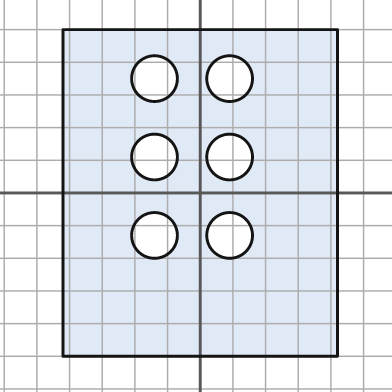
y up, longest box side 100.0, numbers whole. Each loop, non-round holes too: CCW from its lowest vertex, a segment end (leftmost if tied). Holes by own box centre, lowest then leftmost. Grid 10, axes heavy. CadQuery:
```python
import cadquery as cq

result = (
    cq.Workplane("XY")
    .moveTo(-42.0, -50.0)
    .lineTo(42.0, -50.0)
    .lineTo(42.0, 50.0)
    .lineTo(-42.0, 50.0)
    .close()
    .moveTo(-14.0, -13.0)
    .circle(7.0)
    .moveTo(9.0, -13.0)
    .circle(7.0)
    .moveTo(-14.0, 11.0)
    .circle(7.0)
    .moveTo(9.0, 11.0)
    .circle(7.0)
    .moveTo(-14.0, 35.0)
    .circle(7.0)
    .moveTo(9.0, 35.0)
    .circle(7.0)
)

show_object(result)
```